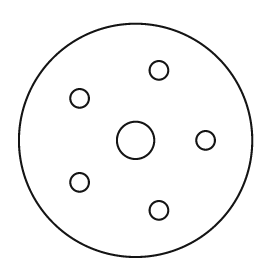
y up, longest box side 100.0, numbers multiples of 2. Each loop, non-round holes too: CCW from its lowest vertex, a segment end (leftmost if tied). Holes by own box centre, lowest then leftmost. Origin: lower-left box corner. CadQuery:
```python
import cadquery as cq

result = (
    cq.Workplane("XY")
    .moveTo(50.0, 50.0)
    .circle(50.0)
    .moveTo(60.0, 20.0)
    .circle(4.0)
    .moveTo(26.0, 32.0)
    .circle(4.0)
    .moveTo(50.0, 50.0)
    .circle(8.0)
    .moveTo(80.0, 50.0)
    .circle(4.0)
    .moveTo(26.0, 68.0)
    .circle(4.0)
    .moveTo(60.0, 80.0)
    .circle(4.0)
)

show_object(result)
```